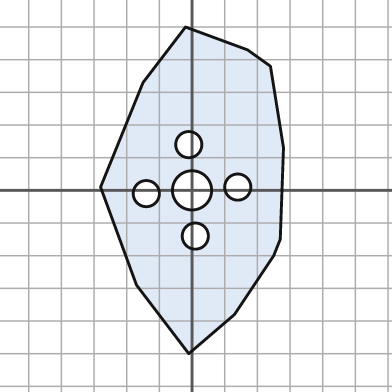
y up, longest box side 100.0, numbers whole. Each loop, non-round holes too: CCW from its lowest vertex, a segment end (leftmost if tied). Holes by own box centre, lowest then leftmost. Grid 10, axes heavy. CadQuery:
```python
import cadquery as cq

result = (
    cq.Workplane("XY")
    .moveTo(-1.0, -50.0)
    .lineTo(13.0, -38.0)
    .lineTo(25.0, -20.0)
    .lineTo(27.0, -15.0)
    .lineTo(28.0, 13.0)
    .lineTo(24.0, 38.0)
    .lineTo(17.0, 43.0)
    .lineTo(-2.0, 50.0)
    .lineTo(-15.0, 33.0)
    .lineTo(-28.0, 1.0)
    .lineTo(-17.0, -29.0)
    .close()
    .moveTo(1.0, -14.0)
    .circle(4.0)
    .moveTo(-14.0, -1.0)
    .circle(4.0)
    .moveTo(0.0, 0.0)
    .circle(6.0)
    .moveTo(14.0, 1.0)
    .circle(4.0)
    .moveTo(-1.0, 14.0)
    .circle(4.0)
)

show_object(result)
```